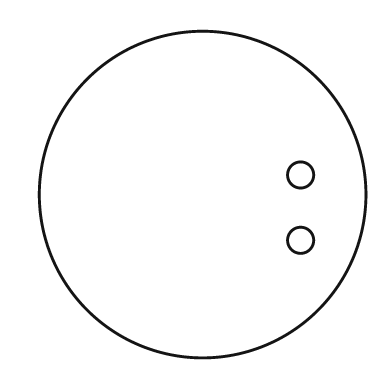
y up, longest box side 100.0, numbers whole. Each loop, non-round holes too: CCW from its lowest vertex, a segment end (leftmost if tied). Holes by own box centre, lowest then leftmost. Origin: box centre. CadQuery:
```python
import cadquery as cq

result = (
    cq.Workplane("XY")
    .moveTo(0.0, 0.0)
    .circle(50.0)
    .moveTo(30.0, -14.0)
    .circle(4.0)
    .moveTo(30.0, 6.0)
    .circle(4.0)
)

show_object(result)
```